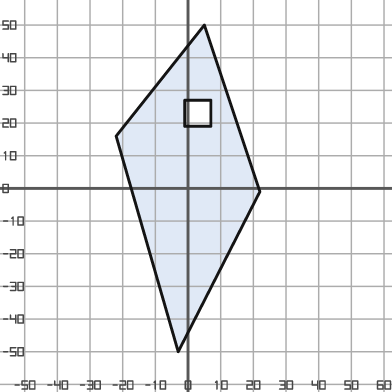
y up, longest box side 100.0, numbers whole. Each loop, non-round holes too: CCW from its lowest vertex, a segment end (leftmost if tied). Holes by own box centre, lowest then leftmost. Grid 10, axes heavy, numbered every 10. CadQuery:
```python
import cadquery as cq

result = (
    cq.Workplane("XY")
    .moveTo(-3.0, -50.0)
    .lineTo(22.0, -1.0)
    .lineTo(5.0, 50.0)
    .lineTo(-22.0, 16.0)
    .close()
    .moveTo(-1.0, 19.0)
    .lineTo(7.0, 19.0)
    .lineTo(7.0, 27.0)
    .lineTo(-1.0, 27.0)
    .close()
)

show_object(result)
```